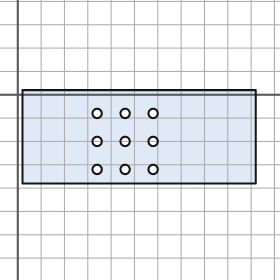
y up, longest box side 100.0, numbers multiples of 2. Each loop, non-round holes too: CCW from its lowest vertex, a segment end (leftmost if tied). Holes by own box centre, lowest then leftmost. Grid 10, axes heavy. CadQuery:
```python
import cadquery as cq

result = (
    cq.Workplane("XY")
    .moveTo(2.0, -38.0)
    .lineTo(102.0, -38.0)
    .lineTo(102.0, 2.0)
    .lineTo(2.0, 2.0)
    .close()
    .moveTo(34.0, -32.0)
    .circle(2.0)
    .moveTo(46.0, -32.0)
    .circle(2.0)
    .moveTo(58.0, -32.0)
    .circle(2.0)
    .moveTo(34.0, -20.0)
    .circle(2.0)
    .moveTo(46.0, -20.0)
    .circle(2.0)
    .moveTo(58.0, -20.0)
    .circle(2.0)
    .moveTo(34.0, -8.0)
    .circle(2.0)
    .moveTo(46.0, -8.0)
    .circle(2.0)
    .moveTo(58.0, -8.0)
    .circle(2.0)
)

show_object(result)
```